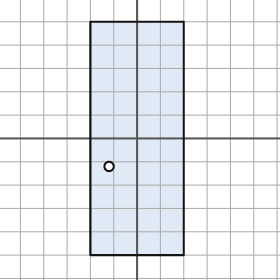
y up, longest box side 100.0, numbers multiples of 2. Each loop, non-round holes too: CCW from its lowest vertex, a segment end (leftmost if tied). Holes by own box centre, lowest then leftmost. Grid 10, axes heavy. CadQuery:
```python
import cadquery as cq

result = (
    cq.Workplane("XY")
    .moveTo(-20.0, -50.0)
    .lineTo(20.0, -50.0)
    .lineTo(20.0, 50.0)
    .lineTo(-20.0, 50.0)
    .close()
    .moveTo(-12.0, -12.0)
    .circle(2.0)
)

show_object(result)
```